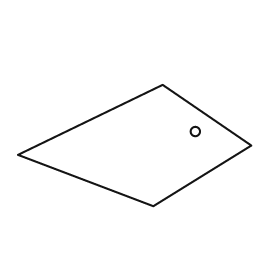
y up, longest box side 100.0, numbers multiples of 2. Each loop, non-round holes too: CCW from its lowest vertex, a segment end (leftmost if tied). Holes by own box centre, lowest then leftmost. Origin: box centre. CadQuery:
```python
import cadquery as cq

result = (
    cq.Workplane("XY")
    .moveTo(8.0, -26.0)
    .lineTo(50.0, 0.0)
    .lineTo(12.0, 26.0)
    .lineTo(-50.0, -4.0)
    .close()
    .moveTo(26.0, 6.0)
    .circle(2.0)
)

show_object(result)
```